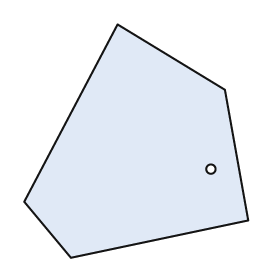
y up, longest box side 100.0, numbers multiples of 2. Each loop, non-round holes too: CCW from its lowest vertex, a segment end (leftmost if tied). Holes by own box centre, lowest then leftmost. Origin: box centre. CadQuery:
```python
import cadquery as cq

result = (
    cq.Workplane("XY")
    .moveTo(-28.0, -50.0)
    .lineTo(48.0, -34.0)
    .lineTo(38.0, 22.0)
    .lineTo(-8.0, 50.0)
    .lineTo(-48.0, -26.0)
    .close()
    .moveTo(32.0, -12.0)
    .circle(2.0)
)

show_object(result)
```